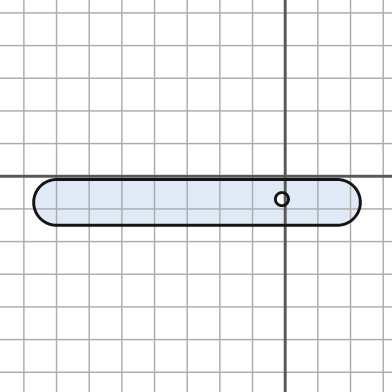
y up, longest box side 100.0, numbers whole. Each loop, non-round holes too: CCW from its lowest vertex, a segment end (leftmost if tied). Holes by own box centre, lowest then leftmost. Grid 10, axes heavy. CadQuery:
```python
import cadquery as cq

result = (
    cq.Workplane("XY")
    .moveTo(-70.0, -15.0)
    .lineTo(16.0, -15.0)
    .threePointArc((23.0, -8.0), (16.0, -1.0))
    .lineTo(-70.0, -1.0)
    .threePointArc((-77.0, -8.0), (-70.0, -15.0))
    .close()
    .moveTo(-1.0, -7.0)
    .circle(2.0)
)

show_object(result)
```